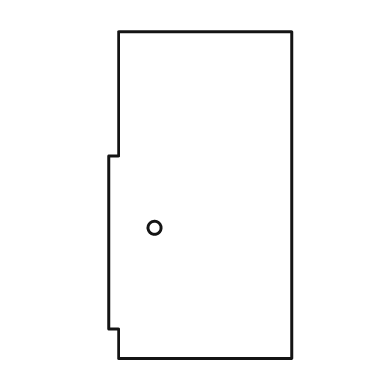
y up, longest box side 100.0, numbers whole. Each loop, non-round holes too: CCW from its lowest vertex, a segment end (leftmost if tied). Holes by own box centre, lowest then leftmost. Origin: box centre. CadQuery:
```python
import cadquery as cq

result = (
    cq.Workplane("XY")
    .moveTo(-25.0, -50.0)
    .lineTo(28.0, -50.0)
    .lineTo(28.0, 50.0)
    .lineTo(-25.0, 50.0)
    .lineTo(-25.0, 12.0)
    .lineTo(-28.0, 12.0)
    .lineTo(-28.0, -41.0)
    .lineTo(-25.0, -41.0)
    .close()
    .moveTo(-14.0, -10.0)
    .circle(2.0)
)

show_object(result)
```